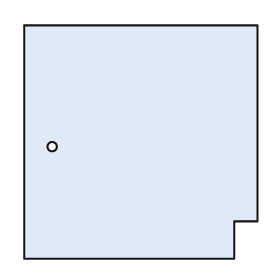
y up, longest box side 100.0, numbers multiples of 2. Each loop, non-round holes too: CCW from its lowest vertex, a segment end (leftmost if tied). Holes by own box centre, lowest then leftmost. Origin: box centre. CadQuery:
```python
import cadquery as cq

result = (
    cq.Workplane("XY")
    .moveTo(-50.0, -50.0)
    .lineTo(40.0, -50.0)
    .lineTo(40.0, -34.0)
    .lineTo(50.0, -34.0)
    .lineTo(50.0, 50.0)
    .lineTo(-50.0, 50.0)
    .close()
    .moveTo(-38.0, -2.0)
    .circle(2.0)
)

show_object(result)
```